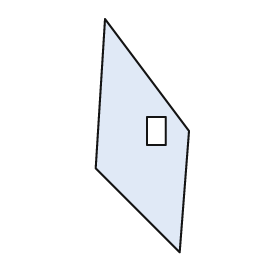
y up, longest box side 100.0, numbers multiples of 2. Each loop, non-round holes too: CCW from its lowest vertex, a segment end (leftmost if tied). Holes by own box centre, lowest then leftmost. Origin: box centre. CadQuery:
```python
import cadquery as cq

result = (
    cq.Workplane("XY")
    .moveTo(16.0, -50.0)
    .lineTo(20.0, 2.0)
    .lineTo(-16.0, 50.0)
    .lineTo(-20.0, -14.0)
    .close()
    .moveTo(2.0, -4.0)
    .lineTo(10.0, -4.0)
    .lineTo(10.0, 8.0)
    .lineTo(2.0, 8.0)
    .close()
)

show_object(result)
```